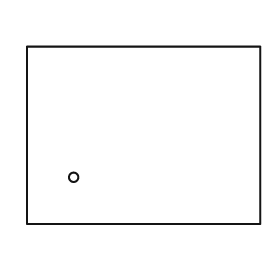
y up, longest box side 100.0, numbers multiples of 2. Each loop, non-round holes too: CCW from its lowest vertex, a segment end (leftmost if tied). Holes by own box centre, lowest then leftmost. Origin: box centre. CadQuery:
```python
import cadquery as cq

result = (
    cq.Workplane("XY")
    .moveTo(-50.0, -38.0)
    .lineTo(50.0, -38.0)
    .lineTo(50.0, 38.0)
    .lineTo(-50.0, 38.0)
    .close()
    .moveTo(-30.0, -18.0)
    .circle(2.0)
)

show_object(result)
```